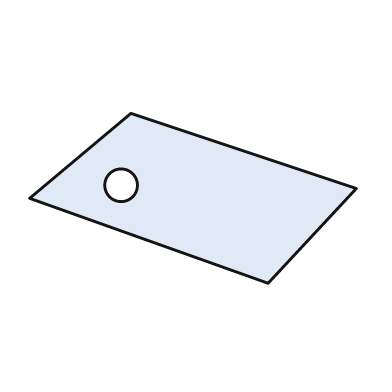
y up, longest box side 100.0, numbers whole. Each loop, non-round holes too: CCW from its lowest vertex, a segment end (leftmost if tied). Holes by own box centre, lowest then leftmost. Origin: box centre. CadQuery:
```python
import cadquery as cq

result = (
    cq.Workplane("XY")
    .moveTo(23.0, -26.0)
    .lineTo(50.0, 3.0)
    .lineTo(-19.0, 26.0)
    .lineTo(-50.0, 0.0)
    .close()
    .moveTo(-22.0, 4.0)
    .circle(5.0)
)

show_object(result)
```